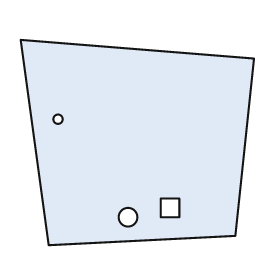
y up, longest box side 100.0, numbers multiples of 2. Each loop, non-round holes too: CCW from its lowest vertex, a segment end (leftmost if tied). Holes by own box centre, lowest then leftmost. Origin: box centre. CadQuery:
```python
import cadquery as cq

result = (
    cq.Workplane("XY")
    .moveTo(-38.0, -44.0)
    .lineTo(42.0, -40.0)
    .lineTo(50.0, 36.0)
    .lineTo(-50.0, 44.0)
    .close()
    .moveTo(-4.0, -32.0)
    .circle(4.0)
    .moveTo(10.0, -32.0)
    .lineTo(18.0, -32.0)
    .lineTo(18.0, -24.0)
    .lineTo(10.0, -24.0)
    .close()
    .moveTo(-34.0, 10.0)
    .circle(2.0)
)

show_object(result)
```